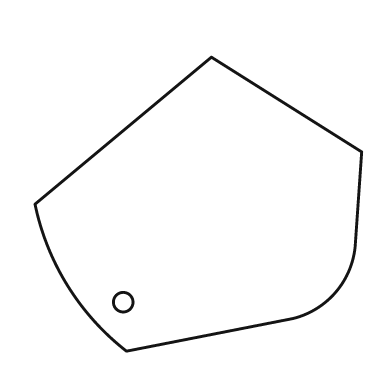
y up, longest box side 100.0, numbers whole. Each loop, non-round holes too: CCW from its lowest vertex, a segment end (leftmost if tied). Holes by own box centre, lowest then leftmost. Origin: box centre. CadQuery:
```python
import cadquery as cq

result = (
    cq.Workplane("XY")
    .moveTo(-22.0, -45.0)
    .lineTo(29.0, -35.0)
    .threePointArc((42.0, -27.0), (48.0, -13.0))
    .lineTo(50.0, 16.0)
    .lineTo(4.0, 45.0)
    .lineTo(-50.0, 0.0)
    .threePointArc((-40.0, -25.0), (-22.0, -45.0))
    .close()
    .moveTo(-23.0, -30.0)
    .circle(3.0)
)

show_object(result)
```